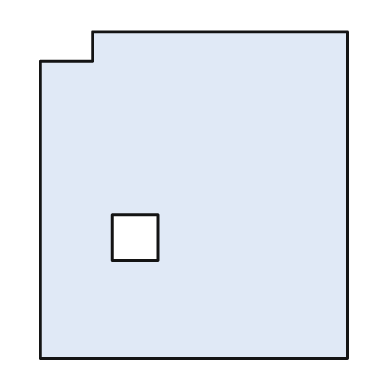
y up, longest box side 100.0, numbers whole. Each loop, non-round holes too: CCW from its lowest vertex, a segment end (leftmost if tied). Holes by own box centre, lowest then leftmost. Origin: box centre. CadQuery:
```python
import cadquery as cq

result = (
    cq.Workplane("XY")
    .moveTo(-47.0, -50.0)
    .lineTo(47.0, -50.0)
    .lineTo(47.0, 50.0)
    .lineTo(-31.0, 50.0)
    .lineTo(-31.0, 41.0)
    .lineTo(-47.0, 41.0)
    .close()
    .moveTo(-25.0, -20.0)
    .lineTo(-11.0, -20.0)
    .lineTo(-11.0, -6.0)
    .lineTo(-25.0, -6.0)
    .close()
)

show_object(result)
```